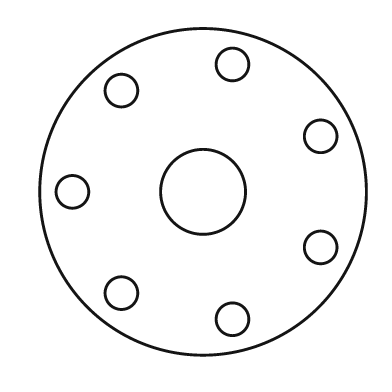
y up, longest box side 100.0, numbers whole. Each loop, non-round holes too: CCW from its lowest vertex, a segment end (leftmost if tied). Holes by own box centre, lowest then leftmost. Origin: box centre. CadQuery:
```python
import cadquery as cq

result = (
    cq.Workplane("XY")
    .moveTo(0.0, 0.0)
    .circle(50.0)
    .moveTo(9.0, -39.0)
    .circle(5.0)
    .moveTo(-25.0, -31.0)
    .circle(5.0)
    .moveTo(36.0, -17.0)
    .circle(5.0)
    .moveTo(-40.0, 0.0)
    .circle(5.0)
    .moveTo(0.0, 0.0)
    .circle(13.0)
    .moveTo(36.0, 17.0)
    .circle(5.0)
    .moveTo(-25.0, 31.0)
    .circle(5.0)
    .moveTo(9.0, 39.0)
    .circle(5.0)
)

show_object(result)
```